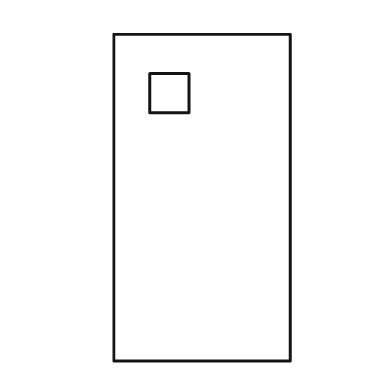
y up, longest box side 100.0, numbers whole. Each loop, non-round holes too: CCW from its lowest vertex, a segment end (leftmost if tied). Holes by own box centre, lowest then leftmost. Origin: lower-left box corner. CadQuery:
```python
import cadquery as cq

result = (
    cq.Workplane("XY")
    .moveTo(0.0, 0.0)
    .lineTo(54.0, 0.0)
    .lineTo(54.0, 100.0)
    .lineTo(0.0, 100.0)
    .close()
    .moveTo(11.0, 76.0)
    .lineTo(23.0, 76.0)
    .lineTo(23.0, 88.0)
    .lineTo(11.0, 88.0)
    .close()
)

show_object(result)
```